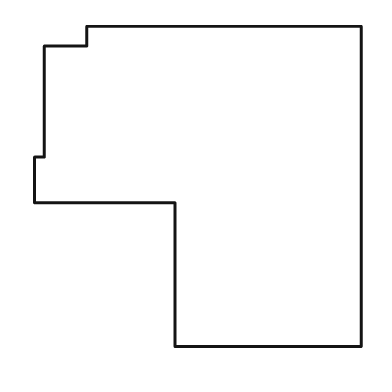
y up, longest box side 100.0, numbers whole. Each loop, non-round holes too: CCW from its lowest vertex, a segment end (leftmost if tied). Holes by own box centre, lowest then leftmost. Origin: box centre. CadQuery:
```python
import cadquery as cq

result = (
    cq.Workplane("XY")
    .moveTo(-7.0, -49.0)
    .lineTo(50.0, -49.0)
    .lineTo(50.0, 49.0)
    .lineTo(-34.0, 49.0)
    .lineTo(-34.0, 43.0)
    .lineTo(-47.0, 43.0)
    .lineTo(-47.0, 9.0)
    .lineTo(-50.0, 9.0)
    .lineTo(-50.0, -5.0)
    .lineTo(-7.0, -5.0)
    .close()
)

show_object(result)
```